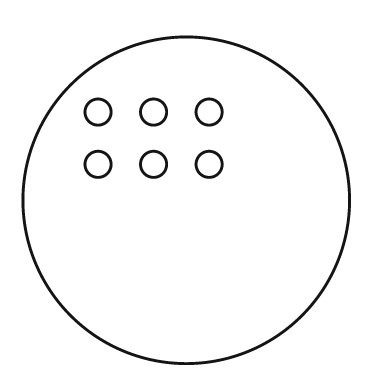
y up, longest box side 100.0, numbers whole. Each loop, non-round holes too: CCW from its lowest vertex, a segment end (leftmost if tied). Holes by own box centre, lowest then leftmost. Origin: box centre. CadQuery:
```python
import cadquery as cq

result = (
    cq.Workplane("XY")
    .moveTo(0.0, 0.0)
    .circle(50.0)
    .moveTo(-27.0, 11.0)
    .circle(4.0)
    .moveTo(-10.0, 11.0)
    .circle(4.0)
    .moveTo(7.0, 11.0)
    .circle(4.0)
    .moveTo(-27.0, 27.0)
    .circle(4.0)
    .moveTo(-10.0, 27.0)
    .circle(4.0)
    .moveTo(7.0, 27.0)
    .circle(4.0)
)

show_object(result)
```